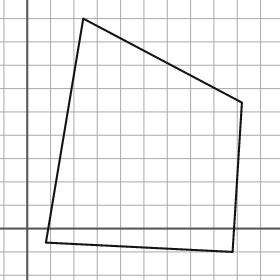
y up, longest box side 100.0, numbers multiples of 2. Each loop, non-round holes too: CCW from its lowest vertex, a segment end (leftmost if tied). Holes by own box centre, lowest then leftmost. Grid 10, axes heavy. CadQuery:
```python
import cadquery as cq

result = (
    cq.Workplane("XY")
    .moveTo(88.0, -10.0)
    .lineTo(92.0, 54.0)
    .lineTo(24.0, 90.0)
    .lineTo(8.0, -6.0)
    .close()
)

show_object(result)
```